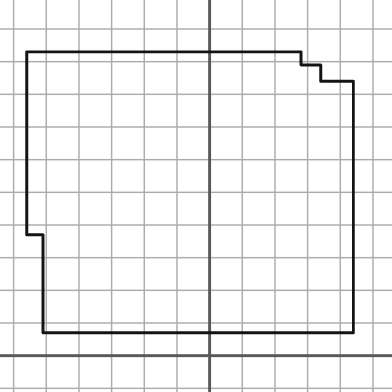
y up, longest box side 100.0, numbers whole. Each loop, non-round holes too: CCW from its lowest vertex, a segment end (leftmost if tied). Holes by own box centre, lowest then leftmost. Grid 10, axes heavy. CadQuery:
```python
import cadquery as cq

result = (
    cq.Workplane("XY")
    .moveTo(-51.0, 7.0)
    .lineTo(44.0, 7.0)
    .lineTo(44.0, 84.0)
    .lineTo(34.0, 84.0)
    .lineTo(34.0, 89.0)
    .lineTo(28.0, 89.0)
    .lineTo(28.0, 93.0)
    .lineTo(-56.0, 93.0)
    .lineTo(-56.0, 37.0)
    .lineTo(-51.0, 37.0)
    .close()
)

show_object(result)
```